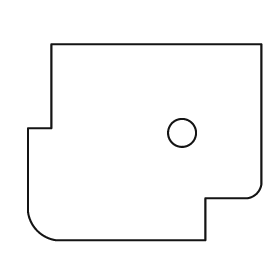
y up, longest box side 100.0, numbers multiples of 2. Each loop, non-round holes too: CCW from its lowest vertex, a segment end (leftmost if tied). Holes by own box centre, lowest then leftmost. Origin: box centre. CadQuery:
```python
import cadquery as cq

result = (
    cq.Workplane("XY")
    .moveTo(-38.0, -42.0)
    .lineTo(26.0, -42.0)
    .lineTo(26.0, -24.0)
    .lineTo(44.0, -24.0)
    .threePointArc((48.0, -22.0), (50.0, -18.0))
    .lineTo(50.0, 42.0)
    .lineTo(-40.0, 42.0)
    .lineTo(-40.0, 6.0)
    .lineTo(-50.0, 6.0)
    .lineTo(-50.0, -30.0)
    .threePointArc((-46.0, -38.0), (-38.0, -42.0))
    .close()
    .moveTo(16.0, 4.0)
    .circle(6.0)
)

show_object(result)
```